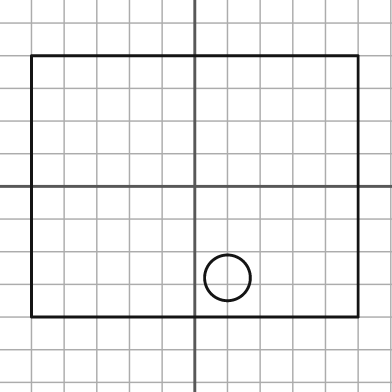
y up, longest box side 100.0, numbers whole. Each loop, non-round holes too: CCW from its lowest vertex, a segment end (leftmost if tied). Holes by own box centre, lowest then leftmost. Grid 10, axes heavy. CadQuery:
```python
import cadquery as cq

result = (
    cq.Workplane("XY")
    .moveTo(-50.0, -40.0)
    .lineTo(50.0, -40.0)
    .lineTo(50.0, 40.0)
    .lineTo(-50.0, 40.0)
    .close()
    .moveTo(10.0, -28.0)
    .circle(7.0)
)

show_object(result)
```